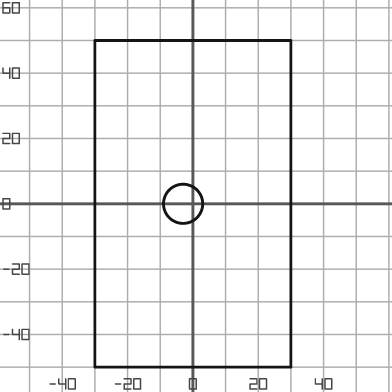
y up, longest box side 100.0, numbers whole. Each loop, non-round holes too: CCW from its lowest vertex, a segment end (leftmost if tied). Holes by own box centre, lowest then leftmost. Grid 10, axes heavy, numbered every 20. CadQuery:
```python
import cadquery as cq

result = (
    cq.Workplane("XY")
    .moveTo(-30.0, -50.0)
    .lineTo(30.0, -50.0)
    .lineTo(30.0, 50.0)
    .lineTo(-30.0, 50.0)
    .close()
    .moveTo(-3.0, 0.0)
    .circle(6.0)
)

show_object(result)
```